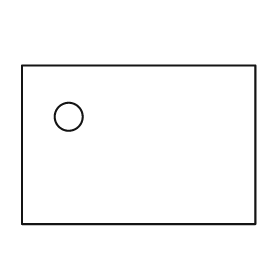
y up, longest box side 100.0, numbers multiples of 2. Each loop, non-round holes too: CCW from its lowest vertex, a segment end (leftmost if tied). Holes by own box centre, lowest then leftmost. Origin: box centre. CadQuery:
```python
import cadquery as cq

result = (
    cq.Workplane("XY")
    .moveTo(-50.0, -34.0)
    .lineTo(50.0, -34.0)
    .lineTo(50.0, 34.0)
    .lineTo(-50.0, 34.0)
    .close()
    .moveTo(-30.0, 12.0)
    .circle(6.0)
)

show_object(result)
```